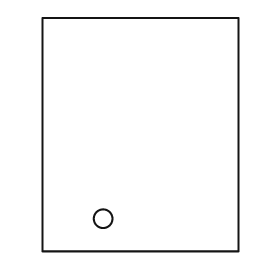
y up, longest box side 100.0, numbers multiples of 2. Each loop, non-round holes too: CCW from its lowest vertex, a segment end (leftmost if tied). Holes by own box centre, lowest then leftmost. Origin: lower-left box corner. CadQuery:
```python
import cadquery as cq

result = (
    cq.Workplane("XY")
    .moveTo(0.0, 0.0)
    .lineTo(84.0, 0.0)
    .lineTo(84.0, 100.0)
    .lineTo(0.0, 100.0)
    .close()
    .moveTo(26.0, 14.0)
    .circle(4.0)
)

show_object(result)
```